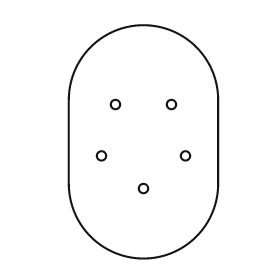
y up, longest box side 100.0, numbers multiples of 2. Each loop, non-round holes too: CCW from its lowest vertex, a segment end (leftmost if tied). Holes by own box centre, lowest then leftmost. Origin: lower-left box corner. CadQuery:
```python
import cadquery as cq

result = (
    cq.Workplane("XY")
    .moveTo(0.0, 32.0)
    .threePointArc((32.0, 0.0), (64.0, 32.0))
    .lineTo(64.0, 68.0)
    .threePointArc((32.0, 100.0), (0.0, 68.0))
    .close()
    .moveTo(32.0, 30.0)
    .circle(2.0)
    .moveTo(14.0, 44.0)
    .circle(2.0)
    .moveTo(50.0, 44.0)
    .circle(2.0)
    .moveTo(20.0, 66.0)
    .circle(2.0)
    .moveTo(44.0, 66.0)
    .circle(2.0)
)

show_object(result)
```